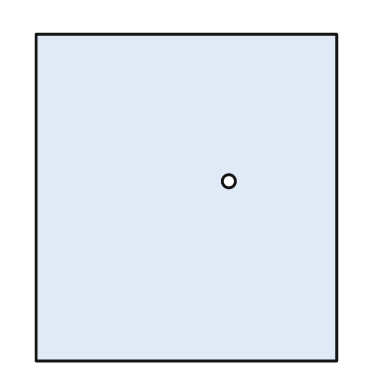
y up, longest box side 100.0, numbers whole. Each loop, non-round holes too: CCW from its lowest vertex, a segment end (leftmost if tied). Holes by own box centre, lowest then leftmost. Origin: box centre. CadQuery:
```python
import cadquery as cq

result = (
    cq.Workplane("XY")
    .moveTo(-46.0, -50.0)
    .lineTo(46.0, -50.0)
    .lineTo(46.0, 50.0)
    .lineTo(-46.0, 50.0)
    .close()
    .moveTo(13.0, 5.0)
    .circle(2.0)
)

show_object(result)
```